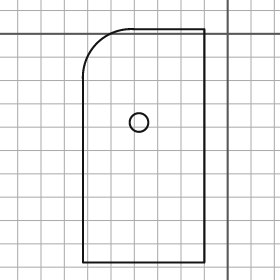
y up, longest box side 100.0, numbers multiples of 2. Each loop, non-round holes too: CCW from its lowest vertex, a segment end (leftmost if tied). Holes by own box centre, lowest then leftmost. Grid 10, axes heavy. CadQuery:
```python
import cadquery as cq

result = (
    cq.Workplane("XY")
    .moveTo(-62.0, -98.0)
    .lineTo(-10.0, -98.0)
    .lineTo(-10.0, 2.0)
    .lineTo(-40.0, 2.0)
    .threePointArc((-56.0, -4.0), (-62.0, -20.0))
    .close()
    .moveTo(-38.0, -38.0)
    .circle(4.0)
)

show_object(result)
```